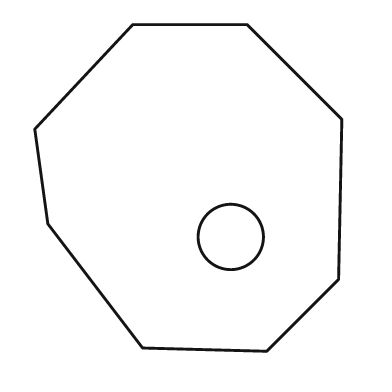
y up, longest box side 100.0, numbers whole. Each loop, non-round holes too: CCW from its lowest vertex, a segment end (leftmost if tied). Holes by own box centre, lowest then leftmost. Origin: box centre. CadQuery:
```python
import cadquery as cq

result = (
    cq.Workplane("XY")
    .moveTo(24.0, -50.0)
    .lineTo(46.0, -28.0)
    .lineTo(47.0, 21.0)
    .lineTo(18.0, 50.0)
    .lineTo(-17.0, 50.0)
    .lineTo(-47.0, 18.0)
    .lineTo(-43.0, -11.0)
    .lineTo(-14.0, -49.0)
    .close()
    .moveTo(13.0, -15.0)
    .circle(10.0)
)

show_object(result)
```